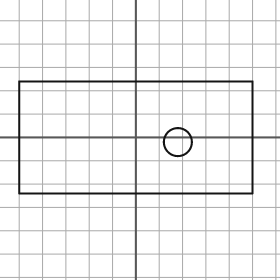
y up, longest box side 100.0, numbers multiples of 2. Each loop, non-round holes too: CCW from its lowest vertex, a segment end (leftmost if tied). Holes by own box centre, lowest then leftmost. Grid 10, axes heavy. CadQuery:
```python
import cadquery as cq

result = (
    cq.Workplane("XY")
    .moveTo(-50.0, -24.0)
    .lineTo(50.0, -24.0)
    .lineTo(50.0, 24.0)
    .lineTo(-50.0, 24.0)
    .close()
    .moveTo(18.0, -2.0)
    .circle(6.0)
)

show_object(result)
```